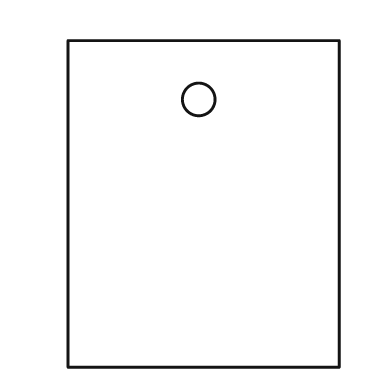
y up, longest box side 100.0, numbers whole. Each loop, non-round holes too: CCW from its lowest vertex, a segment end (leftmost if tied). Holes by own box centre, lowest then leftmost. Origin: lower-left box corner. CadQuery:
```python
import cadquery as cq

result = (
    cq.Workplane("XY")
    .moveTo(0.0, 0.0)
    .lineTo(83.0, 0.0)
    .lineTo(83.0, 100.0)
    .lineTo(0.0, 100.0)
    .close()
    .moveTo(40.0, 82.0)
    .circle(5.0)
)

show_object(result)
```